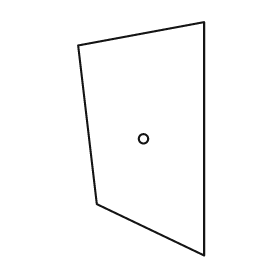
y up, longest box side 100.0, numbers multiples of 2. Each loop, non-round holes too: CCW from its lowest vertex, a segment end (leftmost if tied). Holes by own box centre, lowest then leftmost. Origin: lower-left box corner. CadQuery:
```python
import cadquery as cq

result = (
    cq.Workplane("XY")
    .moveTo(54.0, 0.0)
    .lineTo(54.0, 100.0)
    .lineTo(0.0, 90.0)
    .lineTo(8.0, 22.0)
    .close()
    .moveTo(28.0, 50.0)
    .circle(2.0)
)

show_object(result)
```